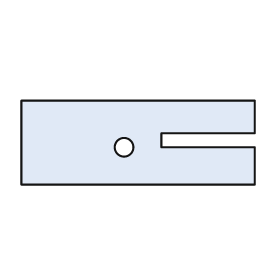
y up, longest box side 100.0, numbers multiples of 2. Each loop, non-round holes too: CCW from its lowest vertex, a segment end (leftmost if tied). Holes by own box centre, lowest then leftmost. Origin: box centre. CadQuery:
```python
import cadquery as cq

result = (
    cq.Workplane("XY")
    .moveTo(-50.0, -18.0)
    .lineTo(50.0, -18.0)
    .lineTo(50.0, -2.0)
    .lineTo(10.0, -2.0)
    .lineTo(10.0, 4.0)
    .lineTo(50.0, 4.0)
    .lineTo(50.0, 18.0)
    .lineTo(-50.0, 18.0)
    .close()
    .moveTo(-6.0, -2.0)
    .circle(4.0)
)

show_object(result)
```